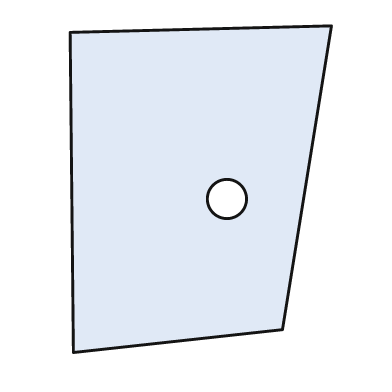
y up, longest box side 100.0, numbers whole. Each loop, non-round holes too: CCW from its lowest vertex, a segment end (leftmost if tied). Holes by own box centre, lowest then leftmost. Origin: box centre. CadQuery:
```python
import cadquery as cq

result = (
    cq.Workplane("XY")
    .moveTo(-39.0, -50.0)
    .lineTo(25.0, -43.0)
    .lineTo(40.0, 50.0)
    .lineTo(-40.0, 48.0)
    .close()
    .moveTo(8.0, -3.0)
    .circle(6.0)
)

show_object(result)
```